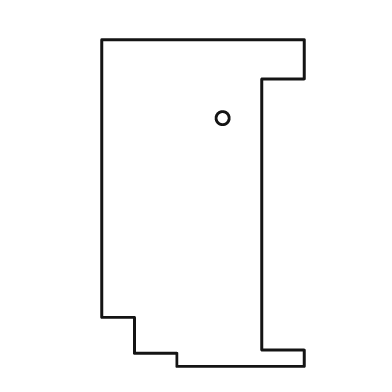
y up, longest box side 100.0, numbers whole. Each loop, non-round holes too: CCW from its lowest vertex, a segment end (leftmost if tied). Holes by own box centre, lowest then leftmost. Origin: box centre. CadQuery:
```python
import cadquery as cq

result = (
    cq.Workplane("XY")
    .moveTo(-8.0, -50.0)
    .lineTo(31.0, -50.0)
    .lineTo(31.0, -45.0)
    .lineTo(18.0, -45.0)
    .lineTo(18.0, 38.0)
    .lineTo(31.0, 38.0)
    .lineTo(31.0, 50.0)
    .lineTo(-31.0, 50.0)
    .lineTo(-31.0, -35.0)
    .lineTo(-21.0, -35.0)
    .lineTo(-21.0, -46.0)
    .lineTo(-8.0, -46.0)
    .close()
    .moveTo(6.0, 26.0)
    .circle(2.0)
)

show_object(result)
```